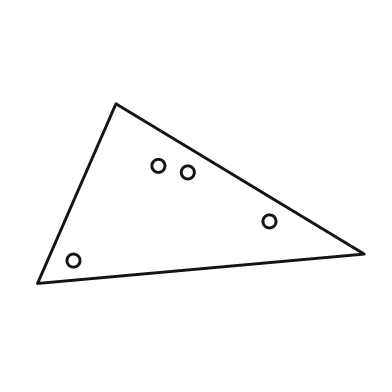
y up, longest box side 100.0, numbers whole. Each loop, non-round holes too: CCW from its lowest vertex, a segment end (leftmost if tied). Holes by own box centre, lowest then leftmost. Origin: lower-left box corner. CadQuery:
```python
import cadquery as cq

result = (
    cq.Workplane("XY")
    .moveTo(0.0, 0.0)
    .lineTo(100.0, 9.0)
    .lineTo(24.0, 55.0)
    .close()
    .moveTo(11.0, 7.0)
    .circle(2.0)
    .moveTo(71.0, 19.0)
    .circle(2.0)
    .moveTo(46.0, 34.0)
    .circle(2.0)
    .moveTo(37.0, 36.0)
    .circle(2.0)
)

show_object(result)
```